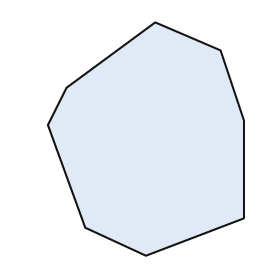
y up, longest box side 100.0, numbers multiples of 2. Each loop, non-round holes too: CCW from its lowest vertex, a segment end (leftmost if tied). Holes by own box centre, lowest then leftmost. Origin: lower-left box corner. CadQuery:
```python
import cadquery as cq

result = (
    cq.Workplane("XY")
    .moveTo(42.0, 0.0)
    .lineTo(84.0, 16.0)
    .lineTo(84.0, 58.0)
    .lineTo(74.0, 88.0)
    .lineTo(46.0, 100.0)
    .lineTo(8.0, 72.0)
    .lineTo(0.0, 56.0)
    .lineTo(16.0, 12.0)
    .close()
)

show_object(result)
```